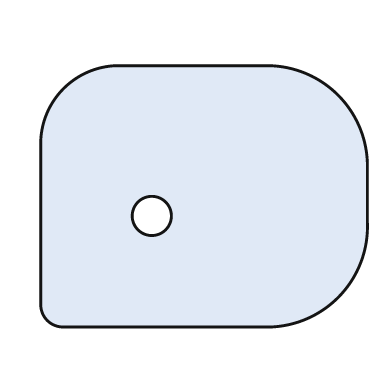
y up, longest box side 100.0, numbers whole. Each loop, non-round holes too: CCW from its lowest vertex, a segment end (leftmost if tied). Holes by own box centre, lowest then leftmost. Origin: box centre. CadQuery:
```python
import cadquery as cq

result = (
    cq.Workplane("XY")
    .moveTo(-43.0, -40.0)
    .lineTo(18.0, -40.0)
    .threePointArc((41.0, -31.0), (50.0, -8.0))
    .lineTo(50.0, 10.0)
    .threePointArc((41.0, 31.0), (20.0, 40.0))
    .lineTo(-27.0, 40.0)
    .threePointArc((-43.0, 33.0), (-50.0, 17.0))
    .lineTo(-50.0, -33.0)
    .threePointArc((-48.0, -38.0), (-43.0, -40.0))
    .close()
    .moveTo(-16.0, -6.0)
    .circle(6.0)
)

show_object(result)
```